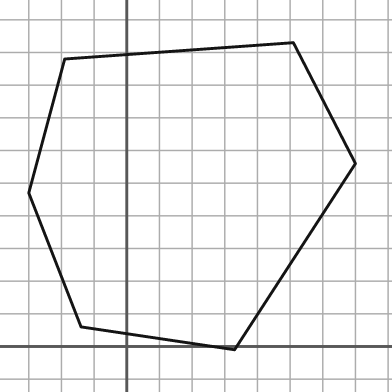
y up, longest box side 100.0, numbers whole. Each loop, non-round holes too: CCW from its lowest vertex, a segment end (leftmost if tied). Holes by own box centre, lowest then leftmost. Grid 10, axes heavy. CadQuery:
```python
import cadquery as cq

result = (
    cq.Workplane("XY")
    .moveTo(33.0, -1.0)
    .lineTo(70.0, 56.0)
    .lineTo(51.0, 93.0)
    .lineTo(-19.0, 88.0)
    .lineTo(-30.0, 47.0)
    .lineTo(-14.0, 6.0)
    .close()
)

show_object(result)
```